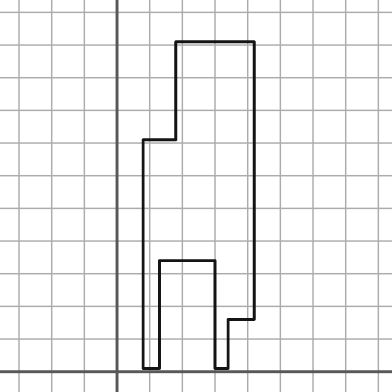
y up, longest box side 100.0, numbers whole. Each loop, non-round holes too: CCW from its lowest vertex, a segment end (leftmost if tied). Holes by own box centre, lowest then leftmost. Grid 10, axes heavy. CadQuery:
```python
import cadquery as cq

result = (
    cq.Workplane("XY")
    .moveTo(8.0, 1.0)
    .lineTo(13.0, 1.0)
    .lineTo(13.0, 34.0)
    .lineTo(30.0, 34.0)
    .lineTo(30.0, 1.0)
    .lineTo(34.0, 1.0)
    .lineTo(34.0, 16.0)
    .lineTo(42.0, 16.0)
    .lineTo(42.0, 101.0)
    .lineTo(18.0, 101.0)
    .lineTo(18.0, 71.0)
    .lineTo(8.0, 71.0)
    .close()
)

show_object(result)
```